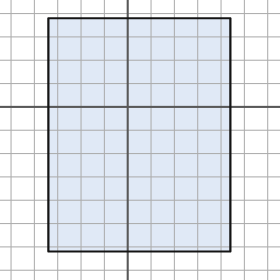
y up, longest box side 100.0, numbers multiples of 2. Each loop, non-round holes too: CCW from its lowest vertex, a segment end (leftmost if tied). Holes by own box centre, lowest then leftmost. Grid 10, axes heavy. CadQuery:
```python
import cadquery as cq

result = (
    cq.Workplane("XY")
    .moveTo(-34.0, -62.0)
    .lineTo(44.0, -62.0)
    .lineTo(44.0, 38.0)
    .lineTo(-34.0, 38.0)
    .close()
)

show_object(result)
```